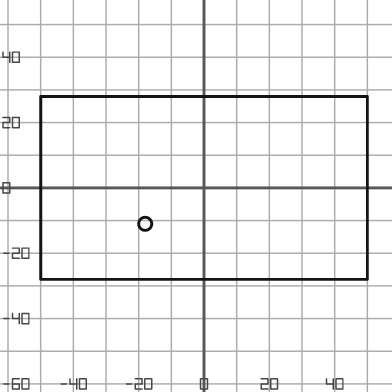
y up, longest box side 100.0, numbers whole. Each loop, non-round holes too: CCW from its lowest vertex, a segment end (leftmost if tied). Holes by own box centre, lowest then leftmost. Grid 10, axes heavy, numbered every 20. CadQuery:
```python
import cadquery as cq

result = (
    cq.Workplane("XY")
    .moveTo(-50.0, -28.0)
    .lineTo(50.0, -28.0)
    .lineTo(50.0, 28.0)
    .lineTo(-50.0, 28.0)
    .close()
    .moveTo(-18.0, -11.0)
    .circle(2.0)
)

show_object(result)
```